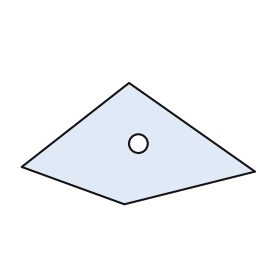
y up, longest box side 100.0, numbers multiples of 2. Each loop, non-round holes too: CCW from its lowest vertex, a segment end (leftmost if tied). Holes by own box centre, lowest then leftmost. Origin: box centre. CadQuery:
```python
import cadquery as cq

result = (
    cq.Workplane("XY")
    .moveTo(-6.0, -26.0)
    .lineTo(50.0, -12.0)
    .lineTo(-4.0, 26.0)
    .lineTo(-50.0, -10.0)
    .close()
    .moveTo(0.0, 0.0)
    .circle(4.0)
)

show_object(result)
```